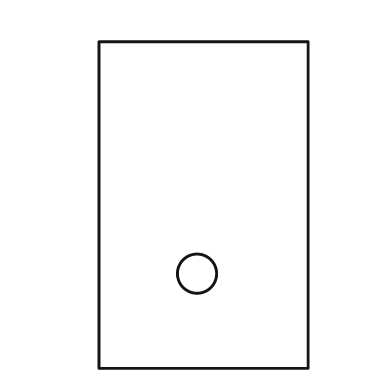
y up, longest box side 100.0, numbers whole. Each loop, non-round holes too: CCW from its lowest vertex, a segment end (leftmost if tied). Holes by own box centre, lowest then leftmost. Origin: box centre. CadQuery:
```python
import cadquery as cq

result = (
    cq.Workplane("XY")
    .moveTo(-32.0, -50.0)
    .lineTo(32.0, -50.0)
    .lineTo(32.0, 50.0)
    .lineTo(-32.0, 50.0)
    .close()
    .moveTo(-2.0, -21.0)
    .circle(6.0)
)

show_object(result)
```